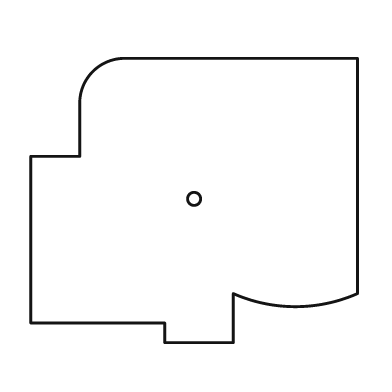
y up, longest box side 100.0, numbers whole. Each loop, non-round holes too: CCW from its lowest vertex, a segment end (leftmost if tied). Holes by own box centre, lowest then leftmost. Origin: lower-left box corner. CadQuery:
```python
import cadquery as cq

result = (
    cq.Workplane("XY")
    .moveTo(41.0, 0.0)
    .lineTo(62.0, 0.0)
    .lineTo(62.0, 15.0)
    .threePointArc((81.0, 11.0), (100.0, 15.0))
    .lineTo(100.0, 87.0)
    .lineTo(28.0, 87.0)
    .threePointArc((19.0, 83.0), (15.0, 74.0))
    .lineTo(15.0, 57.0)
    .lineTo(0.0, 57.0)
    .lineTo(0.0, 6.0)
    .lineTo(41.0, 6.0)
    .close()
    .moveTo(50.0, 44.0)
    .circle(2.0)
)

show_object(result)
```